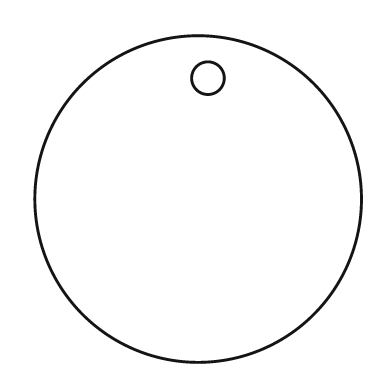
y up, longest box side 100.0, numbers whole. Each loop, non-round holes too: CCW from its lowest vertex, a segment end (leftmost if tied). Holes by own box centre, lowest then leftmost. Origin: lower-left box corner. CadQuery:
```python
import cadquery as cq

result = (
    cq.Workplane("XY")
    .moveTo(50.0, 50.0)
    .circle(50.0)
    .moveTo(53.0, 87.0)
    .circle(5.0)
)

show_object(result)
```